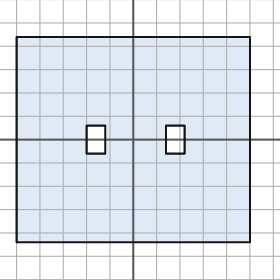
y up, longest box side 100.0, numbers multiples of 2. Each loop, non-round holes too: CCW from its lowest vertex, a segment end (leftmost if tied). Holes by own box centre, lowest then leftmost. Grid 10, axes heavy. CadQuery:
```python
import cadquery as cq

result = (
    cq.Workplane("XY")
    .moveTo(-50.0, -44.0)
    .lineTo(50.0, -44.0)
    .lineTo(50.0, 44.0)
    .lineTo(-50.0, 44.0)
    .close()
    .moveTo(-20.0, -6.0)
    .lineTo(-12.0, -6.0)
    .lineTo(-12.0, 6.0)
    .lineTo(-20.0, 6.0)
    .close()
    .moveTo(14.0, -6.0)
    .lineTo(22.0, -6.0)
    .lineTo(22.0, 6.0)
    .lineTo(14.0, 6.0)
    .close()
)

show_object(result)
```